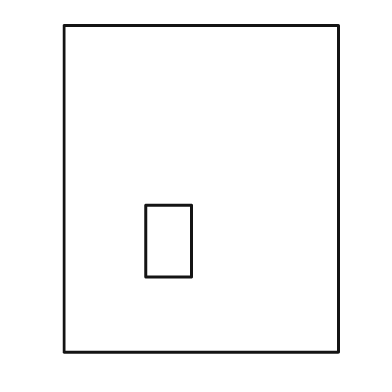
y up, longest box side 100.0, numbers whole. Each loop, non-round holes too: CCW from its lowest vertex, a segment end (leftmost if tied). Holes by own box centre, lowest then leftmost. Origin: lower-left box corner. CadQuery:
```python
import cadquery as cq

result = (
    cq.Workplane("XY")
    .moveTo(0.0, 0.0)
    .lineTo(84.0, 0.0)
    .lineTo(84.0, 100.0)
    .lineTo(0.0, 100.0)
    .close()
    .moveTo(25.0, 23.0)
    .lineTo(39.0, 23.0)
    .lineTo(39.0, 45.0)
    .lineTo(25.0, 45.0)
    .close()
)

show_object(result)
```